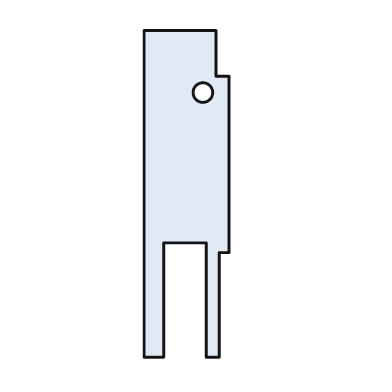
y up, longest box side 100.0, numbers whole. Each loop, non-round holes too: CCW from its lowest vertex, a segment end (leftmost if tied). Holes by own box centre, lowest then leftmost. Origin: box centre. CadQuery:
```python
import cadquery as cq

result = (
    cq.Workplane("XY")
    .moveTo(-13.0, -50.0)
    .lineTo(-7.0, -50.0)
    .lineTo(-7.0, -15.0)
    .lineTo(6.0, -15.0)
    .lineTo(6.0, -50.0)
    .lineTo(10.0, -50.0)
    .lineTo(10.0, -18.0)
    .lineTo(13.0, -18.0)
    .lineTo(13.0, 36.0)
    .lineTo(9.0, 36.0)
    .lineTo(9.0, 50.0)
    .lineTo(-13.0, 50.0)
    .close()
    .moveTo(5.0, 31.0)
    .circle(3.0)
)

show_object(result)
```